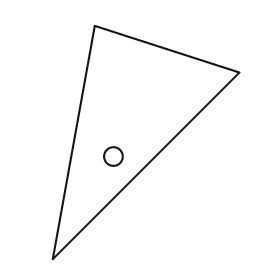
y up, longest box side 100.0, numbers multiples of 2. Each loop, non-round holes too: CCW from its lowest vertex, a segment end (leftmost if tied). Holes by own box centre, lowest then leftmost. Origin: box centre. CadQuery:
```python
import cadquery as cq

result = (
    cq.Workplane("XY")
    .moveTo(-40.0, -50.0)
    .lineTo(40.0, 30.0)
    .lineTo(-22.0, 50.0)
    .close()
    .moveTo(-14.0, -6.0)
    .circle(4.0)
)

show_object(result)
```